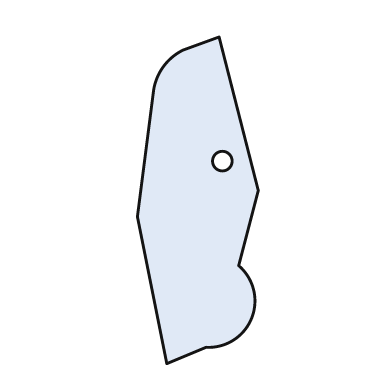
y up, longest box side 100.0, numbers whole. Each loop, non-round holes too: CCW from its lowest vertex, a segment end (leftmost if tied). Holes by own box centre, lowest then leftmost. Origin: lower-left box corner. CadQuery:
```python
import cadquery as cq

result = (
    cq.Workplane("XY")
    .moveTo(9.0, 0.0)
    .lineTo(21.0, 5.0)
    .threePointArc((35.0, 14.0), (31.0, 30.0))
    .lineTo(37.0, 53.0)
    .lineTo(25.0, 100.0)
    .lineTo(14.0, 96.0)
    .threePointArc((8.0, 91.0), (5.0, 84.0))
    .lineTo(0.0, 45.0)
    .close()
    .moveTo(26.0, 62.0)
    .circle(3.0)
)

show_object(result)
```